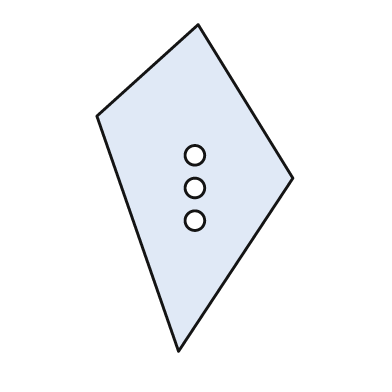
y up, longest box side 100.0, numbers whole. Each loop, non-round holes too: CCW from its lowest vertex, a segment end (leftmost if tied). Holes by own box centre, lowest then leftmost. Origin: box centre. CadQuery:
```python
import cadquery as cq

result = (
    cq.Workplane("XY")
    .moveTo(-5.0, -50.0)
    .lineTo(30.0, 3.0)
    .lineTo(1.0, 50.0)
    .lineTo(-30.0, 22.0)
    .close()
    .moveTo(0.0, -10.0)
    .circle(3.0)
    .moveTo(0.0, 0.0)
    .circle(3.0)
    .moveTo(0.0, 10.0)
    .circle(3.0)
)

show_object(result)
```